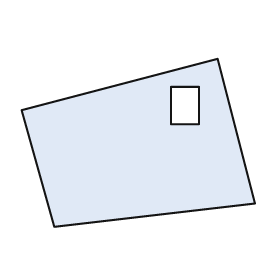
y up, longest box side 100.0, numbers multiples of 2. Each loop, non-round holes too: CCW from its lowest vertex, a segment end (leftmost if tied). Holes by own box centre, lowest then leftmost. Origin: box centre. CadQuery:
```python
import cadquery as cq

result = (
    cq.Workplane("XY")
    .moveTo(-36.0, -36.0)
    .lineTo(50.0, -26.0)
    .lineTo(34.0, 36.0)
    .lineTo(-50.0, 14.0)
    .close()
    .moveTo(14.0, 8.0)
    .lineTo(26.0, 8.0)
    .lineTo(26.0, 24.0)
    .lineTo(14.0, 24.0)
    .close()
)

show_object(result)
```